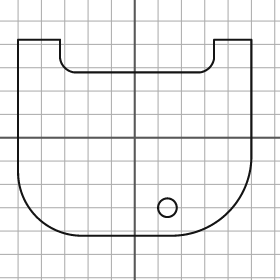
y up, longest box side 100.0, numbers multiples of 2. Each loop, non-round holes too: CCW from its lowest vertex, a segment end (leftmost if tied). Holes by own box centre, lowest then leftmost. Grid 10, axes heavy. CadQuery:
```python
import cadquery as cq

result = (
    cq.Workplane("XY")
    .moveTo(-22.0, -42.0)
    .lineTo(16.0, -42.0)
    .threePointArc((40.0, -32.0), (50.0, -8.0))
    .lineTo(50.0, 42.0)
    .lineTo(34.0, 42.0)
    .lineTo(34.0, 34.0)
    .threePointArc((32.0, 30.0), (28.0, 28.0))
    .lineTo(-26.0, 28.0)
    .threePointArc((-30.0, 30.0), (-32.0, 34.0))
    .lineTo(-32.0, 42.0)
    .lineTo(-50.0, 42.0)
    .lineTo(-50.0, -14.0)
    .threePointArc((-42.0, -34.0), (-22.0, -42.0))
    .close()
    .moveTo(14.0, -30.0)
    .circle(4.0)
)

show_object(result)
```